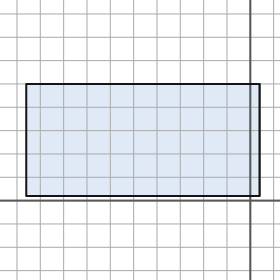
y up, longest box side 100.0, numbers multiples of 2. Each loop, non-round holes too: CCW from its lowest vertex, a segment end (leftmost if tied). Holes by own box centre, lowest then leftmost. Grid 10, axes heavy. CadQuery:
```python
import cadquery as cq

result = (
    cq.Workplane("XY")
    .moveTo(-96.0, 2.0)
    .lineTo(4.0, 2.0)
    .lineTo(4.0, 50.0)
    .lineTo(-96.0, 50.0)
    .close()
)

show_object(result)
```